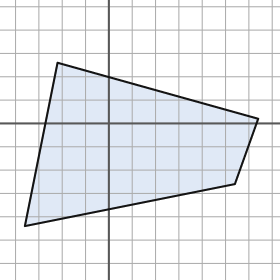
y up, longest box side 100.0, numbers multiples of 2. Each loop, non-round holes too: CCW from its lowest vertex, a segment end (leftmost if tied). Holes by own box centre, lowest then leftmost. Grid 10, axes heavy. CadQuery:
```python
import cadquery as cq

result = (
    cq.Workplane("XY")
    .moveTo(-36.0, -44.0)
    .lineTo(54.0, -26.0)
    .lineTo(64.0, 2.0)
    .lineTo(-22.0, 26.0)
    .close()
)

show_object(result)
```